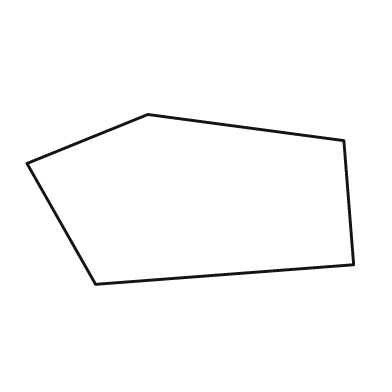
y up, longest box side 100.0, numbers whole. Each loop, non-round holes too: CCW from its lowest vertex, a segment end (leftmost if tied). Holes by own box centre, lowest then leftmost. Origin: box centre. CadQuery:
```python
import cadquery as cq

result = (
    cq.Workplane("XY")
    .moveTo(-29.0, -26.0)
    .lineTo(50.0, -20.0)
    .lineTo(47.0, 18.0)
    .lineTo(-13.0, 26.0)
    .lineTo(-50.0, 11.0)
    .close()
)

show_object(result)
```